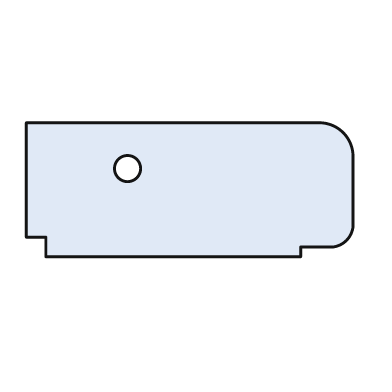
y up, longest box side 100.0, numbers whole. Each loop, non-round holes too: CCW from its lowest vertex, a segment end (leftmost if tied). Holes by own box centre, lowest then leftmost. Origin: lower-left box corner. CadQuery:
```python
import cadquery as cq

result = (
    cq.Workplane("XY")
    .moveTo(6.0, 0.0)
    .lineTo(84.0, 0.0)
    .lineTo(84.0, 3.0)
    .lineTo(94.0, 3.0)
    .threePointArc((98.0, 5.0), (100.0, 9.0))
    .lineTo(100.0, 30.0)
    .threePointArc((97.0, 38.0), (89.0, 41.0))
    .lineTo(0.0, 41.0)
    .lineTo(0.0, 6.0)
    .lineTo(6.0, 6.0)
    .close()
    .moveTo(31.0, 27.0)
    .circle(4.0)
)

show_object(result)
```